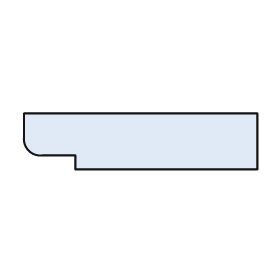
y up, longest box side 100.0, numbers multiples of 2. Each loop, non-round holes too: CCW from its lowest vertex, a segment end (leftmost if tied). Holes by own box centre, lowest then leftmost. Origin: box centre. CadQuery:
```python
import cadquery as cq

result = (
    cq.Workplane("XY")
    .moveTo(-28.0, -12.0)
    .lineTo(50.0, -12.0)
    .lineTo(50.0, 12.0)
    .lineTo(-50.0, 12.0)
    .lineTo(-50.0, 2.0)
    .threePointArc((-48.0, -4.0), (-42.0, -6.0))
    .lineTo(-28.0, -6.0)
    .close()
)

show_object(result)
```